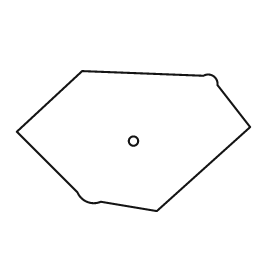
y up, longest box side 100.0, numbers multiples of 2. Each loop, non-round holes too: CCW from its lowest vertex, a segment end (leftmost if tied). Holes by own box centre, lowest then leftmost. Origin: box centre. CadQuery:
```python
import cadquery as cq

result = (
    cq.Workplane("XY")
    .moveTo(10.0, -30.0)
    .lineTo(50.0, 6.0)
    .lineTo(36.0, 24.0)
    .threePointArc((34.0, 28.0), (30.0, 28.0))
    .lineTo(-22.0, 30.0)
    .lineTo(-50.0, 4.0)
    .lineTo(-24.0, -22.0)
    .threePointArc((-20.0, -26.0), (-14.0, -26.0))
    .close()
    .moveTo(0.0, 0.0)
    .circle(2.0)
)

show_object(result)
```